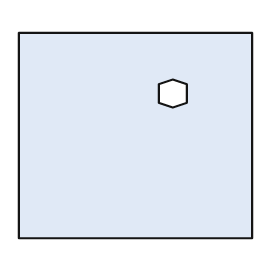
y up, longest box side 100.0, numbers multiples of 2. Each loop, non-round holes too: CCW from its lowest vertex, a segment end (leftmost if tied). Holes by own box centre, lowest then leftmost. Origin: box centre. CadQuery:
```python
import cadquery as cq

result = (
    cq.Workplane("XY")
    .moveTo(-50.0, -44.0)
    .lineTo(50.0, -44.0)
    .lineTo(50.0, 44.0)
    .lineTo(-50.0, 44.0)
    .close()
    .moveTo(16.0, 12.0)
    .lineTo(22.0, 14.0)
    .lineTo(22.0, 22.0)
    .lineTo(16.0, 24.0)
    .lineTo(10.0, 22.0)
    .lineTo(10.0, 14.0)
    .close()
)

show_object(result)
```